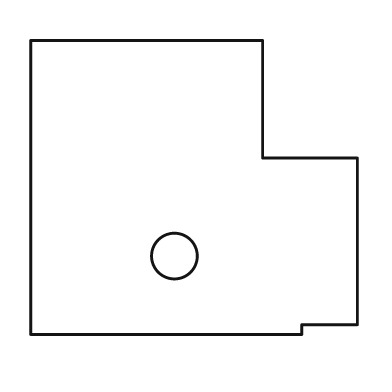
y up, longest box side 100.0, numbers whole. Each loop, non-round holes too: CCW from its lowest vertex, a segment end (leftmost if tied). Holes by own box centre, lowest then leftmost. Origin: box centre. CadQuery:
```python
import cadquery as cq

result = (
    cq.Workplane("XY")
    .moveTo(-50.0, -45.0)
    .lineTo(33.0, -45.0)
    .lineTo(33.0, -42.0)
    .lineTo(50.0, -42.0)
    .lineTo(50.0, 9.0)
    .lineTo(21.0, 9.0)
    .lineTo(21.0, 45.0)
    .lineTo(-50.0, 45.0)
    .close()
    .moveTo(-6.0, -21.0)
    .circle(7.0)
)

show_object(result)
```